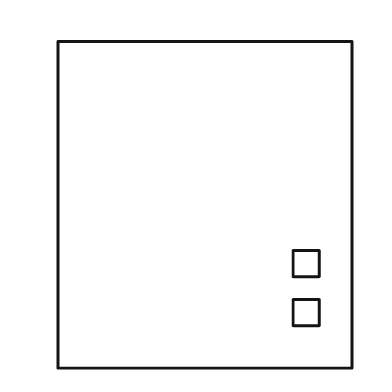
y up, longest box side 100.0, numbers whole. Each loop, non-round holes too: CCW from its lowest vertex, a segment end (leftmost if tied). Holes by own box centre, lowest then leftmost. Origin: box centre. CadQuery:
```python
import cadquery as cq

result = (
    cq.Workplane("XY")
    .moveTo(-45.0, -50.0)
    .lineTo(45.0, -50.0)
    .lineTo(45.0, 50.0)
    .lineTo(-45.0, 50.0)
    .close()
    .moveTo(27.0, -37.0)
    .lineTo(35.0, -37.0)
    .lineTo(35.0, -29.0)
    .lineTo(27.0, -29.0)
    .close()
    .moveTo(27.0, -22.0)
    .lineTo(35.0, -22.0)
    .lineTo(35.0, -14.0)
    .lineTo(27.0, -14.0)
    .close()
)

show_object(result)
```